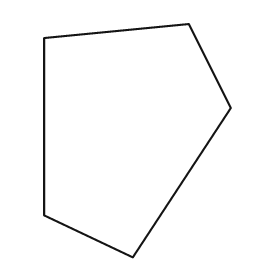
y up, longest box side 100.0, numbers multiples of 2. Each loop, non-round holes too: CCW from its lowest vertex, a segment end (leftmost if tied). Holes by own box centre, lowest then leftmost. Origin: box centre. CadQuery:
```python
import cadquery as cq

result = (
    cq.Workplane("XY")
    .moveTo(-2.0, -50.0)
    .lineTo(40.0, 14.0)
    .lineTo(22.0, 50.0)
    .lineTo(-40.0, 44.0)
    .lineTo(-40.0, -32.0)
    .close()
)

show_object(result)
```